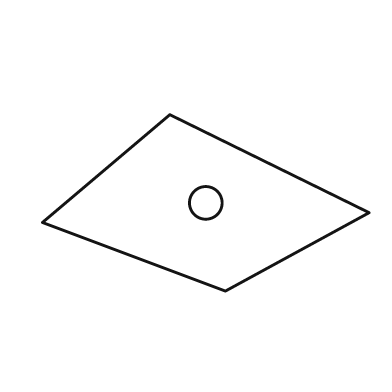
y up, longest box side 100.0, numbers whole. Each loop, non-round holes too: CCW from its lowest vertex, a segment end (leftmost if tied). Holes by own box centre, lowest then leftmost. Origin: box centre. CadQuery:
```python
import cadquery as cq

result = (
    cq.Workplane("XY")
    .moveTo(6.0, -27.0)
    .lineTo(50.0, -3.0)
    .lineTo(-11.0, 27.0)
    .lineTo(-50.0, -6.0)
    .close()
    .moveTo(0.0, 0.0)
    .circle(5.0)
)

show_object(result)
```